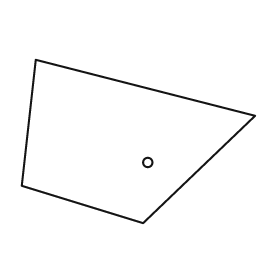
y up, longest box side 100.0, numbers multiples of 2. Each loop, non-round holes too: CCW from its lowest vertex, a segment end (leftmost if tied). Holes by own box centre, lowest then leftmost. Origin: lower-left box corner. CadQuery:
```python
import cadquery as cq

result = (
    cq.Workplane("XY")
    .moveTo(52.0, 0.0)
    .lineTo(100.0, 46.0)
    .lineTo(6.0, 70.0)
    .lineTo(0.0, 16.0)
    .close()
    .moveTo(54.0, 26.0)
    .circle(2.0)
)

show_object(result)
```